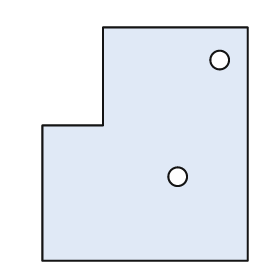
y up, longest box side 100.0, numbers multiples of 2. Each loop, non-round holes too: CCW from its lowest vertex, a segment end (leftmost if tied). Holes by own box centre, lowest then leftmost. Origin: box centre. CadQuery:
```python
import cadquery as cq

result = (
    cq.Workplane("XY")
    .moveTo(-44.0, -50.0)
    .lineTo(44.0, -50.0)
    .lineTo(44.0, 50.0)
    .lineTo(-18.0, 50.0)
    .lineTo(-18.0, 8.0)
    .lineTo(-44.0, 8.0)
    .close()
    .moveTo(14.0, -14.0)
    .circle(4.0)
    .moveTo(32.0, 36.0)
    .circle(4.0)
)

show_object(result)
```